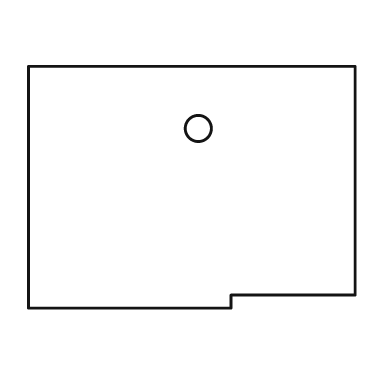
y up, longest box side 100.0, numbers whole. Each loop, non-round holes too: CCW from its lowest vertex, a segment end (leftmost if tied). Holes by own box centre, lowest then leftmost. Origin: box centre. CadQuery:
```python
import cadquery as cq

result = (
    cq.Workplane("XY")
    .moveTo(-50.0, -37.0)
    .lineTo(12.0, -37.0)
    .lineTo(12.0, -33.0)
    .lineTo(50.0, -33.0)
    .lineTo(50.0, 37.0)
    .lineTo(-50.0, 37.0)
    .close()
    .moveTo(2.0, 18.0)
    .circle(4.0)
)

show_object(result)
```